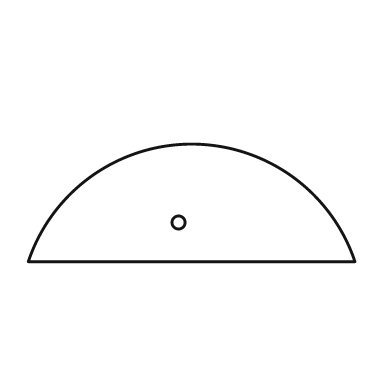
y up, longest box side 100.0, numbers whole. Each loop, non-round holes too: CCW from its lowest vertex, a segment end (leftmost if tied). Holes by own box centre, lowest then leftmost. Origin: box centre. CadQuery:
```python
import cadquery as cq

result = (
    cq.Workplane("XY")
    .moveTo(-50.0, -18.0)
    .lineTo(50.0, -18.0)
    .threePointArc((0.0, 18.0), (-50.0, -18.0))
    .close()
    .moveTo(-4.0, -6.0)
    .circle(2.0)
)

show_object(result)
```